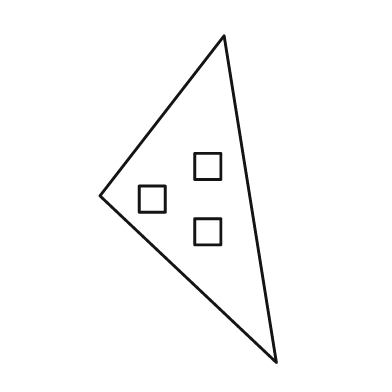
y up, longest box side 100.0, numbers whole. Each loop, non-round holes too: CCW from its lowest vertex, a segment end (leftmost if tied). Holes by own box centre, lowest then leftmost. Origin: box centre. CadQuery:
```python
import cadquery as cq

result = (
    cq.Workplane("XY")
    .moveTo(27.0, -50.0)
    .lineTo(11.0, 50.0)
    .lineTo(-27.0, 1.0)
    .close()
    .moveTo(2.0, -14.0)
    .lineTo(10.0, -14.0)
    .lineTo(10.0, -6.0)
    .lineTo(2.0, -6.0)
    .close()
    .moveTo(-15.0, -4.0)
    .lineTo(-7.0, -4.0)
    .lineTo(-7.0, 4.0)
    .lineTo(-15.0, 4.0)
    .close()
    .moveTo(2.0, 6.0)
    .lineTo(10.0, 6.0)
    .lineTo(10.0, 14.0)
    .lineTo(2.0, 14.0)
    .close()
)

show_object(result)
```